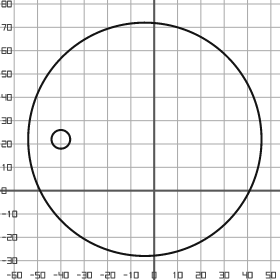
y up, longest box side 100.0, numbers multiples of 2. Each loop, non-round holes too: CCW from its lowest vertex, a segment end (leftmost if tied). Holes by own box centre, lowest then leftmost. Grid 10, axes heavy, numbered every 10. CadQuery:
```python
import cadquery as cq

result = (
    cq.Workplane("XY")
    .moveTo(-4.0, 22.0)
    .circle(50.0)
    .moveTo(-40.0, 22.0)
    .circle(4.0)
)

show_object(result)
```